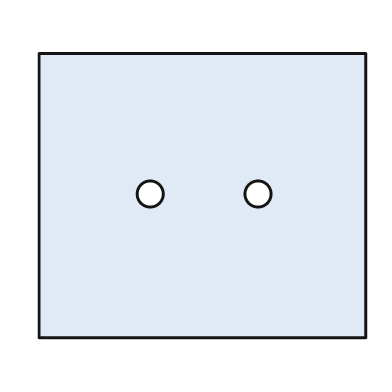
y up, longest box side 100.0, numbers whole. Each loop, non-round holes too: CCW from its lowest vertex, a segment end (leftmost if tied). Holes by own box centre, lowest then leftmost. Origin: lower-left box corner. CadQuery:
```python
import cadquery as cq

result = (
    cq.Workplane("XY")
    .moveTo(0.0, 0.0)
    .lineTo(100.0, 0.0)
    .lineTo(100.0, 87.0)
    .lineTo(0.0, 87.0)
    .close()
    .moveTo(34.0, 44.0)
    .circle(4.0)
    .moveTo(67.0, 44.0)
    .circle(4.0)
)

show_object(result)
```